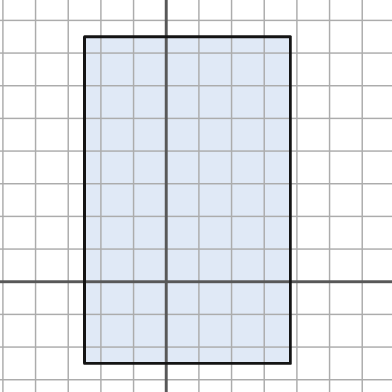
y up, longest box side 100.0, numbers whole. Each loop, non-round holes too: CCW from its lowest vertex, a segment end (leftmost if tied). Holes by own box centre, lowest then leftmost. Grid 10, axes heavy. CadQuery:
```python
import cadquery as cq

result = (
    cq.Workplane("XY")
    .moveTo(-25.0, -25.0)
    .lineTo(38.0, -25.0)
    .lineTo(38.0, 75.0)
    .lineTo(-25.0, 75.0)
    .close()
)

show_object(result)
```